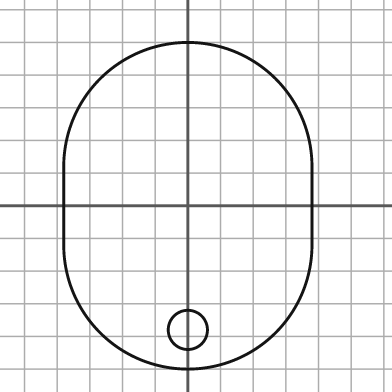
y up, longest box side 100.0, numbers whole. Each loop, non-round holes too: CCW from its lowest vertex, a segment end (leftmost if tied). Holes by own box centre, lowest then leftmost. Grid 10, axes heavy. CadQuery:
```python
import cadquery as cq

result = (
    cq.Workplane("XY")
    .moveTo(-38.0, -12.0)
    .threePointArc((0.0, -50.0), (38.0, -12.0))
    .lineTo(38.0, 12.0)
    .threePointArc((0.0, 50.0), (-38.0, 12.0))
    .close()
    .moveTo(0.0, -38.0)
    .circle(6.0)
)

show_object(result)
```